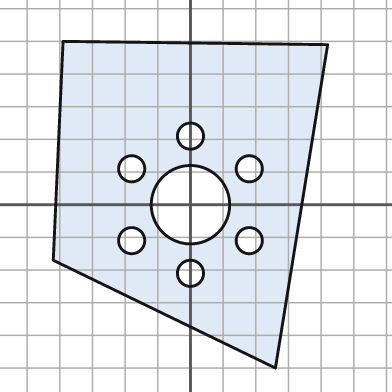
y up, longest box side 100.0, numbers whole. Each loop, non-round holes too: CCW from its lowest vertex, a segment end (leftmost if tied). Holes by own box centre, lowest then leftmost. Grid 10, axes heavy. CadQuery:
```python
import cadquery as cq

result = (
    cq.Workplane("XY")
    .moveTo(26.0, -50.0)
    .lineTo(42.0, 49.0)
    .lineTo(-39.0, 50.0)
    .lineTo(-42.0, -17.0)
    .close()
    .moveTo(0.0, -21.0)
    .circle(4.0)
    .moveTo(-18.0, -11.0)
    .circle(4.0)
    .moveTo(18.0, -11.0)
    .circle(4.0)
    .moveTo(0.0, 0.0)
    .circle(12.0)
    .moveTo(-18.0, 11.0)
    .circle(4.0)
    .moveTo(18.0, 11.0)
    .circle(4.0)
    .moveTo(0.0, 21.0)
    .circle(4.0)
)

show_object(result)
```